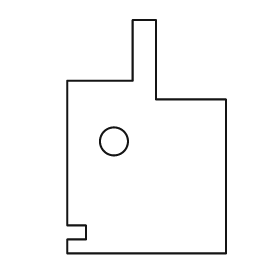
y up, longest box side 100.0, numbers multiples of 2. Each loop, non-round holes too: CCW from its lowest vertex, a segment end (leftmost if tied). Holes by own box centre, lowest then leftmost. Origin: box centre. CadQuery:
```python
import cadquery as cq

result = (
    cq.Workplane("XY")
    .moveTo(-34.0, -50.0)
    .lineTo(34.0, -50.0)
    .lineTo(34.0, 16.0)
    .lineTo(4.0, 16.0)
    .lineTo(4.0, 50.0)
    .lineTo(-6.0, 50.0)
    .lineTo(-6.0, 24.0)
    .lineTo(-34.0, 24.0)
    .lineTo(-34.0, -38.0)
    .lineTo(-26.0, -38.0)
    .lineTo(-26.0, -44.0)
    .lineTo(-34.0, -44.0)
    .close()
    .moveTo(-14.0, -2.0)
    .circle(6.0)
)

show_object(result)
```